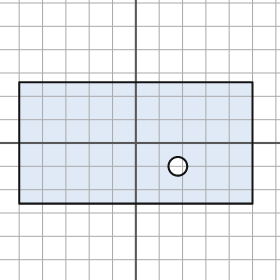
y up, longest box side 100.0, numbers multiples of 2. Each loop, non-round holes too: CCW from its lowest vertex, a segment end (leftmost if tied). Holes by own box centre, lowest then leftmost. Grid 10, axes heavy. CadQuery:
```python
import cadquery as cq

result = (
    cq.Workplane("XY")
    .moveTo(-50.0, -26.0)
    .lineTo(50.0, -26.0)
    .lineTo(50.0, 26.0)
    .lineTo(-50.0, 26.0)
    .close()
    .moveTo(18.0, -10.0)
    .circle(4.0)
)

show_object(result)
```